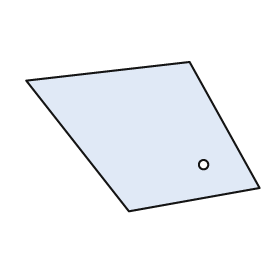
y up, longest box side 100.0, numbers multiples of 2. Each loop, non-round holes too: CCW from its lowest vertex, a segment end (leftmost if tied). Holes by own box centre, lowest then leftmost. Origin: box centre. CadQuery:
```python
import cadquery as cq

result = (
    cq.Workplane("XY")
    .moveTo(-6.0, -32.0)
    .lineTo(50.0, -22.0)
    .lineTo(20.0, 32.0)
    .lineTo(-50.0, 24.0)
    .close()
    .moveTo(26.0, -12.0)
    .circle(2.0)
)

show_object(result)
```